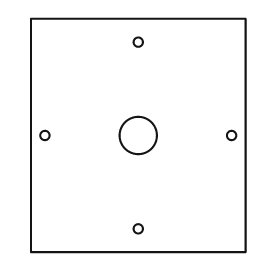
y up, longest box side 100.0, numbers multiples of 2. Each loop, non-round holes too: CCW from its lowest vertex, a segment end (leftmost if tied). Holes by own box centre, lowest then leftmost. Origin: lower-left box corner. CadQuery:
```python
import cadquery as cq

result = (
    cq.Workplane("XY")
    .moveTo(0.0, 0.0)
    .lineTo(92.0, 0.0)
    .lineTo(92.0, 100.0)
    .lineTo(0.0, 100.0)
    .close()
    .moveTo(46.0, 10.0)
    .circle(2.0)
    .moveTo(6.0, 50.0)
    .circle(2.0)
    .moveTo(46.0, 50.0)
    .circle(8.0)
    .moveTo(86.0, 50.0)
    .circle(2.0)
    .moveTo(46.0, 90.0)
    .circle(2.0)
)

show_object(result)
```